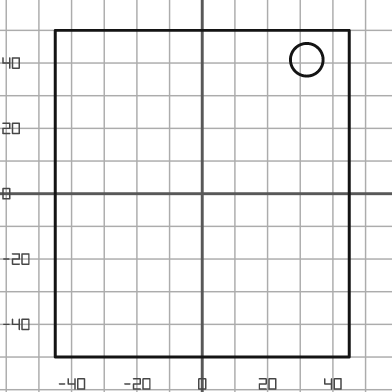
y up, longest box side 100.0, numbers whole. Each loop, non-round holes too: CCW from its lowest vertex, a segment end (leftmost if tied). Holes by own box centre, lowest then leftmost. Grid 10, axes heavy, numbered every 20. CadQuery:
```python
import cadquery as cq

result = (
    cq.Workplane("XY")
    .moveTo(-45.0, -50.0)
    .lineTo(45.0, -50.0)
    .lineTo(45.0, 50.0)
    .lineTo(-45.0, 50.0)
    .close()
    .moveTo(32.0, 41.0)
    .circle(5.0)
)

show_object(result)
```